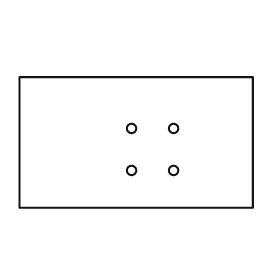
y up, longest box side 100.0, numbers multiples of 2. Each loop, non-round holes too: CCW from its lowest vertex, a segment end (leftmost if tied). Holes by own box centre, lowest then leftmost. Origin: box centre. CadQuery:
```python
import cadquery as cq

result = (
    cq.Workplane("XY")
    .moveTo(-50.0, -28.0)
    .lineTo(50.0, -28.0)
    .lineTo(50.0, 28.0)
    .lineTo(-50.0, 28.0)
    .close()
    .moveTo(-2.0, -12.0)
    .circle(2.0)
    .moveTo(16.0, -12.0)
    .circle(2.0)
    .moveTo(-2.0, 6.0)
    .circle(2.0)
    .moveTo(16.0, 6.0)
    .circle(2.0)
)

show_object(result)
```